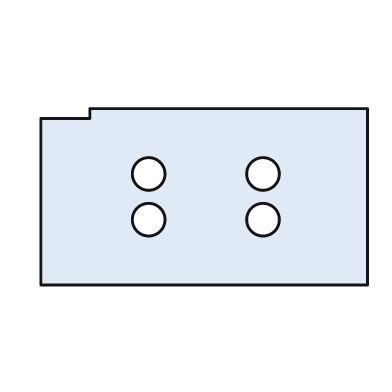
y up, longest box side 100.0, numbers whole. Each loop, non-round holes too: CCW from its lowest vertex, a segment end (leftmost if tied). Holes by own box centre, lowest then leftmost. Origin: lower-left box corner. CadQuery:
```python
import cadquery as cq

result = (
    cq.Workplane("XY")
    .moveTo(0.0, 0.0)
    .lineTo(100.0, 0.0)
    .lineTo(100.0, 54.0)
    .lineTo(15.0, 54.0)
    .lineTo(15.0, 51.0)
    .lineTo(0.0, 51.0)
    .close()
    .moveTo(33.0, 20.0)
    .circle(5.0)
    .moveTo(68.0, 20.0)
    .circle(5.0)
    .moveTo(33.0, 34.0)
    .circle(5.0)
    .moveTo(68.0, 34.0)
    .circle(5.0)
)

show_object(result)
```